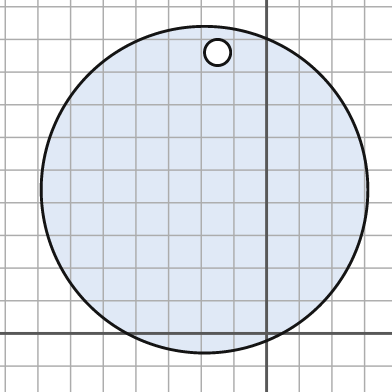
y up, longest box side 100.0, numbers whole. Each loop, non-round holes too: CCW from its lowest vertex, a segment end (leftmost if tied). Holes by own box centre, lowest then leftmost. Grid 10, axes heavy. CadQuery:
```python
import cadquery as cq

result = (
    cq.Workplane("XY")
    .moveTo(-19.0, 44.0)
    .circle(50.0)
    .moveTo(-15.0, 86.0)
    .circle(4.0)
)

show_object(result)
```